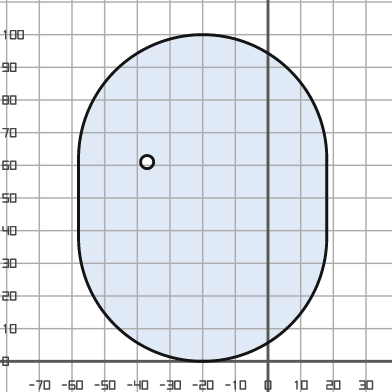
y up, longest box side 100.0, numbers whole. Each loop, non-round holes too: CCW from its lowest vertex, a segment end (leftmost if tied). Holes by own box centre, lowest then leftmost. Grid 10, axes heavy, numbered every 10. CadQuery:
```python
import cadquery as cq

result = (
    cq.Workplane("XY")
    .moveTo(-58.0, 38.0)
    .threePointArc((-20.0, 0.0), (18.0, 38.0))
    .lineTo(18.0, 62.0)
    .threePointArc((-20.0, 100.0), (-58.0, 62.0))
    .close()
    .moveTo(-37.0, 61.0)
    .circle(2.0)
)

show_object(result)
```